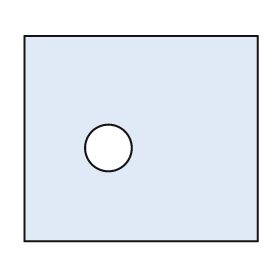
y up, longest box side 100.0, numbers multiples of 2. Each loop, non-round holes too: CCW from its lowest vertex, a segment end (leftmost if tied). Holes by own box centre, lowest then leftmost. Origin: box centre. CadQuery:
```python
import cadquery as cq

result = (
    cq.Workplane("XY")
    .moveTo(-50.0, -44.0)
    .lineTo(50.0, -44.0)
    .lineTo(50.0, 44.0)
    .lineTo(-50.0, 44.0)
    .close()
    .moveTo(-14.0, -4.0)
    .circle(10.0)
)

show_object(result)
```